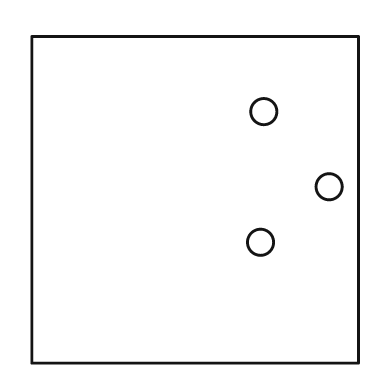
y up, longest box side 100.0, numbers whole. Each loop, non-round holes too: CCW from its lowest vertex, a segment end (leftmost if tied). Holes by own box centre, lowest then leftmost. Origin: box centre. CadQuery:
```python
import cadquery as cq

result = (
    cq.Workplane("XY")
    .moveTo(-50.0, -50.0)
    .lineTo(50.0, -50.0)
    .lineTo(50.0, 50.0)
    .lineTo(-50.0, 50.0)
    .close()
    .moveTo(20.0, -13.0)
    .circle(4.0)
    .moveTo(41.0, 4.0)
    .circle(4.0)
    .moveTo(21.0, 27.0)
    .circle(4.0)
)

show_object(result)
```